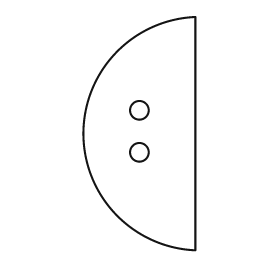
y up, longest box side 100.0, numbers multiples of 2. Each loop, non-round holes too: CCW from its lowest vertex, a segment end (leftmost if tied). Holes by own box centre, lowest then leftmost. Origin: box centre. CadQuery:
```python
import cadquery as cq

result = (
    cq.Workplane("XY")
    .moveTo(24.0, -50.0)
    .lineTo(24.0, 50.0)
    .threePointArc((-24.0, 0.0), (24.0, -50.0))
    .close()
    .moveTo(0.0, -8.0)
    .circle(4.0)
    .moveTo(0.0, 10.0)
    .circle(4.0)
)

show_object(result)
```